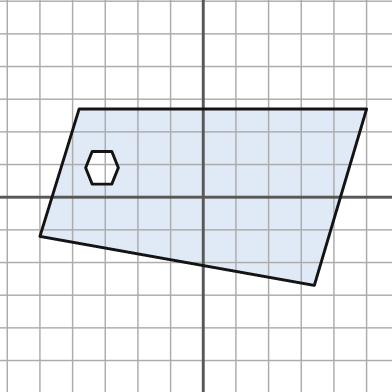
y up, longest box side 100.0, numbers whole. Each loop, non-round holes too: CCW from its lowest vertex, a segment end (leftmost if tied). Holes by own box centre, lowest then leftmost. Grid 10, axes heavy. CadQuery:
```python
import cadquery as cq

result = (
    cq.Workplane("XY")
    .moveTo(34.0, -27.0)
    .lineTo(50.0, 27.0)
    .lineTo(-38.0, 27.0)
    .lineTo(-50.0, -12.0)
    .close()
    .moveTo(-34.0, 4.0)
    .lineTo(-28.0, 4.0)
    .lineTo(-26.0, 9.0)
    .lineTo(-28.0, 14.0)
    .lineTo(-34.0, 14.0)
    .lineTo(-36.0, 9.0)
    .close()
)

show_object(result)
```